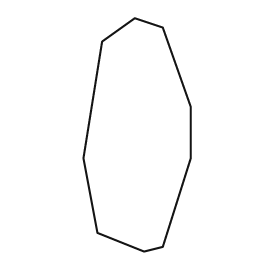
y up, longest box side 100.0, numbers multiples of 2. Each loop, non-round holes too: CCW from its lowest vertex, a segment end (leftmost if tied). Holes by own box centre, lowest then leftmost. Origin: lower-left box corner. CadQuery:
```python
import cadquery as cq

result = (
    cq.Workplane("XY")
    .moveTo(26.0, 0.0)
    .lineTo(34.0, 2.0)
    .lineTo(46.0, 40.0)
    .lineTo(46.0, 62.0)
    .lineTo(34.0, 96.0)
    .lineTo(22.0, 100.0)
    .lineTo(8.0, 90.0)
    .lineTo(0.0, 40.0)
    .lineTo(6.0, 8.0)
    .close()
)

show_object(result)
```